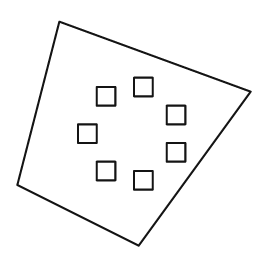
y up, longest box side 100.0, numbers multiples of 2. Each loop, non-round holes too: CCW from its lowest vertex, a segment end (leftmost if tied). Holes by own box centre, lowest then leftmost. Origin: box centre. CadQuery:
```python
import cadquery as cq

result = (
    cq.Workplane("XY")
    .moveTo(2.0, -48.0)
    .lineTo(50.0, 18.0)
    .lineTo(-32.0, 48.0)
    .lineTo(-50.0, -22.0)
    .close()
    .moveTo(0.0, -24.0)
    .lineTo(8.0, -24.0)
    .lineTo(8.0, -16.0)
    .lineTo(0.0, -16.0)
    .close()
    .moveTo(-16.0, -20.0)
    .lineTo(-8.0, -20.0)
    .lineTo(-8.0, -12.0)
    .lineTo(-16.0, -12.0)
    .close()
    .moveTo(14.0, -12.0)
    .lineTo(22.0, -12.0)
    .lineTo(22.0, -4.0)
    .lineTo(14.0, -4.0)
    .close()
    .moveTo(-24.0, -4.0)
    .lineTo(-16.0, -4.0)
    .lineTo(-16.0, 4.0)
    .lineTo(-24.0, 4.0)
    .close()
    .moveTo(14.0, 4.0)
    .lineTo(22.0, 4.0)
    .lineTo(22.0, 12.0)
    .lineTo(14.0, 12.0)
    .close()
    .moveTo(-16.0, 12.0)
    .lineTo(-8.0, 12.0)
    .lineTo(-8.0, 20.0)
    .lineTo(-16.0, 20.0)
    .close()
    .moveTo(0.0, 16.0)
    .lineTo(8.0, 16.0)
    .lineTo(8.0, 24.0)
    .lineTo(0.0, 24.0)
    .close()
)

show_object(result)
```